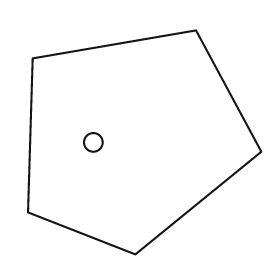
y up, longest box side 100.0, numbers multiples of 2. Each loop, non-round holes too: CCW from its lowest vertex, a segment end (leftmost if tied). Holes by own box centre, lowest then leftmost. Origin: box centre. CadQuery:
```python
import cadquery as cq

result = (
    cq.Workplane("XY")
    .moveTo(-4.0, -48.0)
    .lineTo(50.0, -4.0)
    .lineTo(22.0, 48.0)
    .lineTo(-48.0, 36.0)
    .lineTo(-50.0, -30.0)
    .close()
    .moveTo(-22.0, 0.0)
    .circle(4.0)
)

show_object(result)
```